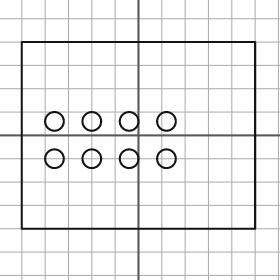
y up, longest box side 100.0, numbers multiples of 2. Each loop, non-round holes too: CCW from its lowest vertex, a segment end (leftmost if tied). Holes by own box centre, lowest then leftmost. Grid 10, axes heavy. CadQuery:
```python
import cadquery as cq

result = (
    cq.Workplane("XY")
    .moveTo(-50.0, -40.0)
    .lineTo(50.0, -40.0)
    .lineTo(50.0, 40.0)
    .lineTo(-50.0, 40.0)
    .close()
    .moveTo(-36.0, -10.0)
    .circle(4.0)
    .moveTo(-20.0, -10.0)
    .circle(4.0)
    .moveTo(-4.0, -10.0)
    .circle(4.0)
    .moveTo(12.0, -10.0)
    .circle(4.0)
    .moveTo(-36.0, 6.0)
    .circle(4.0)
    .moveTo(-20.0, 6.0)
    .circle(4.0)
    .moveTo(-4.0, 6.0)
    .circle(4.0)
    .moveTo(12.0, 6.0)
    .circle(4.0)
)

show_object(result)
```